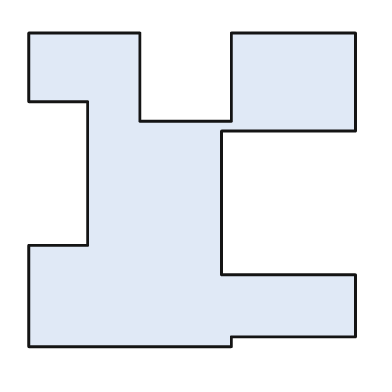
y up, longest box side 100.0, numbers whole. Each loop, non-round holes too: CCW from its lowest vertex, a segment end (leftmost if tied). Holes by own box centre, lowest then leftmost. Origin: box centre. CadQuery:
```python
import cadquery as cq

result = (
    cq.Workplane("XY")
    .moveTo(-50.0, -48.0)
    .lineTo(12.0, -48.0)
    .lineTo(12.0, -45.0)
    .lineTo(50.0, -45.0)
    .lineTo(50.0, -26.0)
    .lineTo(9.0, -26.0)
    .lineTo(9.0, 18.0)
    .lineTo(50.0, 18.0)
    .lineTo(50.0, 48.0)
    .lineTo(12.0, 48.0)
    .lineTo(12.0, 21.0)
    .lineTo(-16.0, 21.0)
    .lineTo(-16.0, 48.0)
    .lineTo(-50.0, 48.0)
    .lineTo(-50.0, 27.0)
    .lineTo(-32.0, 27.0)
    .lineTo(-32.0, -17.0)
    .lineTo(-50.0, -17.0)
    .close()
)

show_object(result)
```